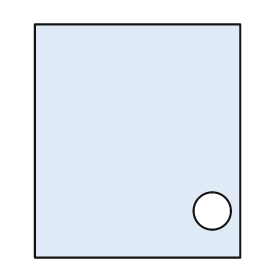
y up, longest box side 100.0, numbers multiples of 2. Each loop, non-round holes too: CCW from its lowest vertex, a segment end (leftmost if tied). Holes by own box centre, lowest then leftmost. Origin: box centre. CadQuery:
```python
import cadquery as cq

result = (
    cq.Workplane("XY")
    .moveTo(-44.0, -50.0)
    .lineTo(44.0, -50.0)
    .lineTo(44.0, 50.0)
    .lineTo(-44.0, 50.0)
    .close()
    .moveTo(32.0, -30.0)
    .circle(8.0)
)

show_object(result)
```